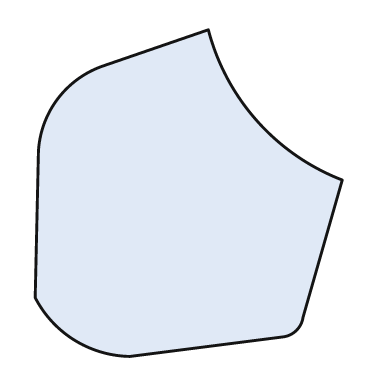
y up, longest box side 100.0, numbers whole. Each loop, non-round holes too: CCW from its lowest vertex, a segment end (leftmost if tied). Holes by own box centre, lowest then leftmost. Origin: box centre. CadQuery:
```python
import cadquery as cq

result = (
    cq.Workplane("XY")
    .moveTo(-18.0, -50.0)
    .lineTo(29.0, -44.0)
    .threePointArc((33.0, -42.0), (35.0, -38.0))
    .lineTo(47.0, 4.0)
    .threePointArc((21.0, 22.0), (6.0, 50.0))
    .lineTo(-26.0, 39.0)
    .threePointArc((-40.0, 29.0), (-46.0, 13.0))
    .lineTo(-47.0, -32.0)
    .threePointArc((-35.0, -45.0), (-18.0, -50.0))
    .close()
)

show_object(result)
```